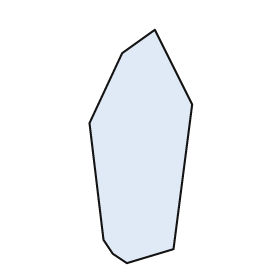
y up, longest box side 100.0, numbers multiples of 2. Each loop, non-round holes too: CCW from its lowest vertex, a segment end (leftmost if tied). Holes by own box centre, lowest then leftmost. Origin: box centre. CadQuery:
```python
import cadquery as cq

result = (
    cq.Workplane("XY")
    .moveTo(-6.0, -50.0)
    .lineTo(14.0, -44.0)
    .lineTo(22.0, 18.0)
    .lineTo(6.0, 50.0)
    .lineTo(-8.0, 40.0)
    .lineTo(-22.0, 10.0)
    .lineTo(-16.0, -40.0)
    .lineTo(-12.0, -46.0)
    .close()
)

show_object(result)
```